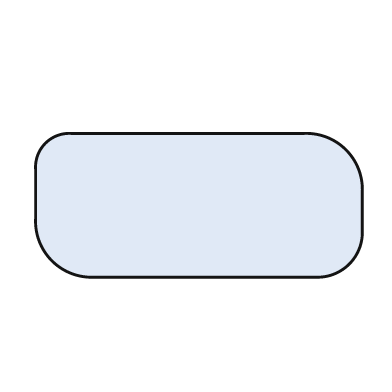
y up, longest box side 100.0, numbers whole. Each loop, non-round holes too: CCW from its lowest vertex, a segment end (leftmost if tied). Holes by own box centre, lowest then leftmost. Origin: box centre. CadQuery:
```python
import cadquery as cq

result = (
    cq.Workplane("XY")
    .moveTo(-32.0, -22.0)
    .lineTo(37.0, -22.0)
    .threePointArc((46.0, -18.0), (50.0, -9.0))
    .lineTo(50.0, 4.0)
    .threePointArc((45.0, 17.0), (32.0, 22.0))
    .lineTo(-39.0, 22.0)
    .threePointArc((-47.0, 19.0), (-50.0, 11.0))
    .lineTo(-50.0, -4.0)
    .threePointArc((-45.0, -17.0), (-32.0, -22.0))
    .close()
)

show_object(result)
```